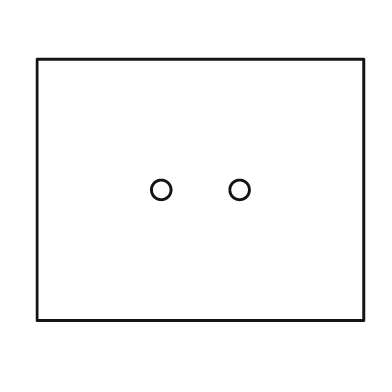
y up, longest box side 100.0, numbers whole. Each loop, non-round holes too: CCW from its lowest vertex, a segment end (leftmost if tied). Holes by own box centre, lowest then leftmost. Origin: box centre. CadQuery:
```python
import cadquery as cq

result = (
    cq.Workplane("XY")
    .moveTo(-50.0, -40.0)
    .lineTo(50.0, -40.0)
    .lineTo(50.0, 40.0)
    .lineTo(-50.0, 40.0)
    .close()
    .moveTo(-12.0, 0.0)
    .circle(3.0)
    .moveTo(12.0, 0.0)
    .circle(3.0)
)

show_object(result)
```